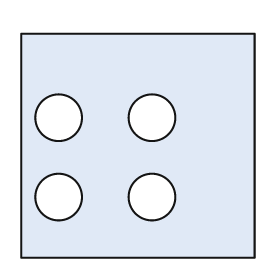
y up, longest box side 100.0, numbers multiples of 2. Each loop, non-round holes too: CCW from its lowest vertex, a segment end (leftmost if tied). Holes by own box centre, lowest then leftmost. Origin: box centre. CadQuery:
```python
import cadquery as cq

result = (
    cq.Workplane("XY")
    .moveTo(-50.0, -48.0)
    .lineTo(50.0, -48.0)
    .lineTo(50.0, 48.0)
    .lineTo(-50.0, 48.0)
    .close()
    .moveTo(-34.0, -22.0)
    .circle(10.0)
    .moveTo(6.0, -22.0)
    .circle(10.0)
    .moveTo(-34.0, 12.0)
    .circle(10.0)
    .moveTo(6.0, 12.0)
    .circle(10.0)
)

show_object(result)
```